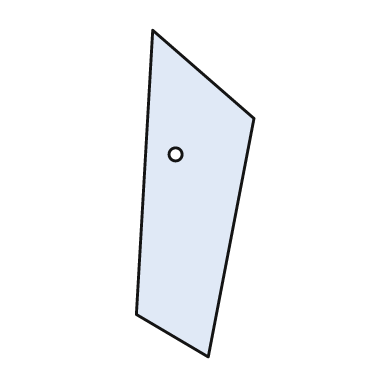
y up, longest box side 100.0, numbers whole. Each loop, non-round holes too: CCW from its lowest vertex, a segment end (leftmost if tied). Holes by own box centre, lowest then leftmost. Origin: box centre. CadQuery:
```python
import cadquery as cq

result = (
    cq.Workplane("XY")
    .moveTo(4.0, -50.0)
    .lineTo(18.0, 23.0)
    .lineTo(-13.0, 50.0)
    .lineTo(-18.0, -37.0)
    .close()
    .moveTo(-6.0, 12.0)
    .circle(2.0)
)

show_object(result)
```